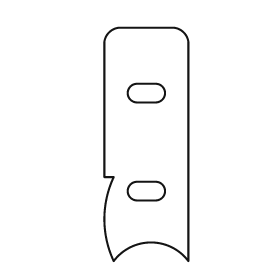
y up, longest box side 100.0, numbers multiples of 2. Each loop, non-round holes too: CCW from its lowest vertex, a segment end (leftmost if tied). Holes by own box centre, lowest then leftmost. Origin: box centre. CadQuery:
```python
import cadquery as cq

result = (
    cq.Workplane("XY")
    .moveTo(-14.0, -50.0)
    .threePointArc((2.0, -42.0), (18.0, -50.0))
    .lineTo(18.0, 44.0)
    .threePointArc((16.0, 48.0), (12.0, 50.0))
    .lineTo(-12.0, 50.0)
    .threePointArc((-16.0, 48.0), (-18.0, 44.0))
    .lineTo(-18.0, -14.0)
    .lineTo(-14.0, -14.0)
    .threePointArc((-18.0, -32.0), (-14.0, -50.0))
    .close()
    .moveTo(-4.0, -24.0)
    .lineTo(4.0, -24.0)
    .threePointArc((8.0, -20.0), (4.0, -16.0))
    .lineTo(-4.0, -16.0)
    .threePointArc((-8.0, -20.0), (-4.0, -24.0))
    .close()
    .moveTo(-4.0, 18.0)
    .lineTo(4.0, 18.0)
    .threePointArc((8.0, 22.0), (4.0, 26.0))
    .lineTo(-4.0, 26.0)
    .threePointArc((-8.0, 22.0), (-4.0, 18.0))
    .close()
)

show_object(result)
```